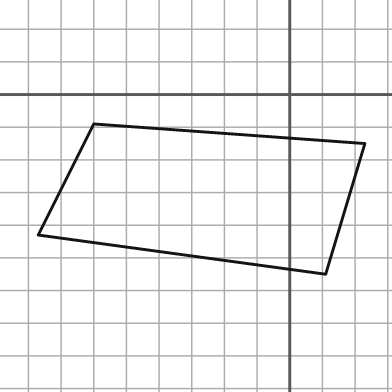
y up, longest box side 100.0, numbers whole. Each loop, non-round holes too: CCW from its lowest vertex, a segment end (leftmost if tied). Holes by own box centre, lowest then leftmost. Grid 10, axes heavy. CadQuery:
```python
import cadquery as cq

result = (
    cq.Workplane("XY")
    .moveTo(11.0, -55.0)
    .lineTo(23.0, -15.0)
    .lineTo(-60.0, -9.0)
    .lineTo(-77.0, -43.0)
    .close()
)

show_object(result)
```